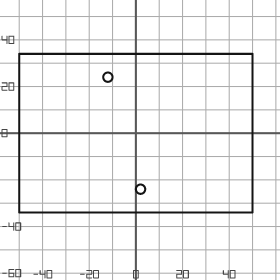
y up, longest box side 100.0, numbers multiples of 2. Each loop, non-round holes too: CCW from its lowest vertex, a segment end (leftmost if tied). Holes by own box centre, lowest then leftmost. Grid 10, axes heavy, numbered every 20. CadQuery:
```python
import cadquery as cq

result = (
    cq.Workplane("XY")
    .moveTo(-50.0, -34.0)
    .lineTo(50.0, -34.0)
    .lineTo(50.0, 34.0)
    .lineTo(-50.0, 34.0)
    .close()
    .moveTo(2.0, -24.0)
    .circle(2.0)
    .moveTo(-12.0, 24.0)
    .circle(2.0)
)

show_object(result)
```